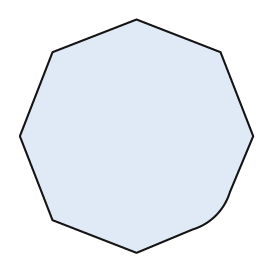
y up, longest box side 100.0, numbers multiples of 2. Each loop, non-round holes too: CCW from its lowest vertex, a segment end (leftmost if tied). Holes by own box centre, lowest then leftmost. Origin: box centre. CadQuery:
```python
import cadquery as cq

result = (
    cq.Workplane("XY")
    .moveTo(0.0, -50.0)
    .lineTo(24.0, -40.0)
    .threePointArc((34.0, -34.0), (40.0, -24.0))
    .lineTo(50.0, 0.0)
    .lineTo(36.0, 36.0)
    .lineTo(0.0, 50.0)
    .lineTo(-36.0, 36.0)
    .lineTo(-50.0, 0.0)
    .lineTo(-36.0, -36.0)
    .close()
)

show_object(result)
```